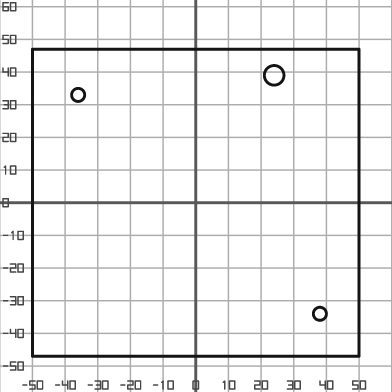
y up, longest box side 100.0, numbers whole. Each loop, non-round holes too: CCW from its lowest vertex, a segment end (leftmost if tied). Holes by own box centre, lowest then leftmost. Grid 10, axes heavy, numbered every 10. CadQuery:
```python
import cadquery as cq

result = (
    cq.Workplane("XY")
    .moveTo(-50.0, -47.0)
    .lineTo(50.0, -47.0)
    .lineTo(50.0, 47.0)
    .lineTo(-50.0, 47.0)
    .close()
    .moveTo(38.0, -34.0)
    .circle(2.0)
    .moveTo(-36.0, 33.0)
    .circle(2.0)
    .moveTo(24.0, 39.0)
    .circle(3.0)
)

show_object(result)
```